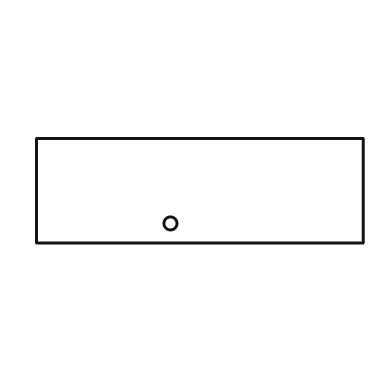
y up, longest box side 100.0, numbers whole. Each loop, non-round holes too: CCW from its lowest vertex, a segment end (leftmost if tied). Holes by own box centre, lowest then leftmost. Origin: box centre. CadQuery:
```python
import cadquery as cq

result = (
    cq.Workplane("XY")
    .moveTo(-50.0, -16.0)
    .lineTo(50.0, -16.0)
    .lineTo(50.0, 16.0)
    .lineTo(-50.0, 16.0)
    .close()
    .moveTo(-9.0, -10.0)
    .circle(2.0)
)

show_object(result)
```